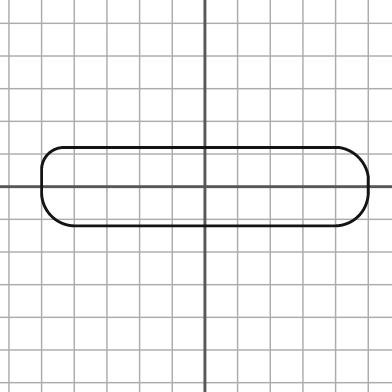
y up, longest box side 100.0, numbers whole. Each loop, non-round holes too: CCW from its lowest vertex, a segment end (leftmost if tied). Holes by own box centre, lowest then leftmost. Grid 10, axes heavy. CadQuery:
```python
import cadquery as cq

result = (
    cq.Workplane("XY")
    .moveTo(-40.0, -12.0)
    .lineTo(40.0, -12.0)
    .threePointArc((47.0, -9.0), (50.0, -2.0))
    .lineTo(50.0, 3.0)
    .threePointArc((47.0, 9.0), (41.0, 12.0))
    .lineTo(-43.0, 12.0)
    .threePointArc((-48.0, 10.0), (-50.0, 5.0))
    .lineTo(-50.0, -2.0)
    .threePointArc((-47.0, -9.0), (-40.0, -12.0))
    .close()
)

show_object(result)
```